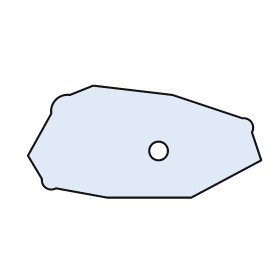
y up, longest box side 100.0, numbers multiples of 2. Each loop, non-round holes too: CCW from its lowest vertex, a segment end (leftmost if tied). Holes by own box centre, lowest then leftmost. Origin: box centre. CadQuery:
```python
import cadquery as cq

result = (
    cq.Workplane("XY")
    .moveTo(-16.0, -24.0)
    .lineTo(20.0, -24.0)
    .lineTo(50.0, -8.0)
    .lineTo(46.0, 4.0)
    .threePointArc((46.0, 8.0), (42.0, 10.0))
    .lineTo(12.0, 20.0)
    .lineTo(-22.0, 24.0)
    .lineTo(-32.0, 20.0)
    .threePointArc((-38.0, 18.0), (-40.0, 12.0))
    .lineTo(-50.0, -6.0)
    .lineTo(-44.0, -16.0)
    .threePointArc((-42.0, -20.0), (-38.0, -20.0))
    .close()
    .moveTo(6.0, -4.0)
    .circle(4.0)
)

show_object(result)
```